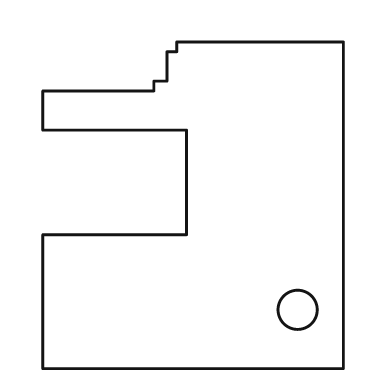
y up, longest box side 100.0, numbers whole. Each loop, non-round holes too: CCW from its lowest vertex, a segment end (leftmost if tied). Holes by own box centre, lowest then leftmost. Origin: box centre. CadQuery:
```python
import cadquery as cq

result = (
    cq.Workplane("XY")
    .moveTo(-46.0, -50.0)
    .lineTo(46.0, -50.0)
    .lineTo(46.0, 50.0)
    .lineTo(-5.0, 50.0)
    .lineTo(-5.0, 47.0)
    .lineTo(-8.0, 47.0)
    .lineTo(-8.0, 38.0)
    .lineTo(-12.0, 38.0)
    .lineTo(-12.0, 35.0)
    .lineTo(-46.0, 35.0)
    .lineTo(-46.0, 23.0)
    .lineTo(-2.0, 23.0)
    .lineTo(-2.0, -9.0)
    .lineTo(-46.0, -9.0)
    .close()
    .moveTo(32.0, -32.0)
    .circle(6.0)
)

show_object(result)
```